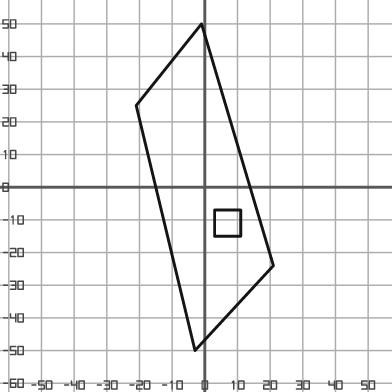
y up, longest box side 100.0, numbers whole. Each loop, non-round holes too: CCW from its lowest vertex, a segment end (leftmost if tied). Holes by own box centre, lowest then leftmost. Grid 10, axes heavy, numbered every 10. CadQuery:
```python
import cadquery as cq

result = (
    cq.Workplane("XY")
    .moveTo(-3.0, -50.0)
    .lineTo(21.0, -24.0)
    .lineTo(-1.0, 50.0)
    .lineTo(-21.0, 25.0)
    .close()
    .moveTo(3.0, -15.0)
    .lineTo(11.0, -15.0)
    .lineTo(11.0, -7.0)
    .lineTo(3.0, -7.0)
    .close()
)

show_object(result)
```